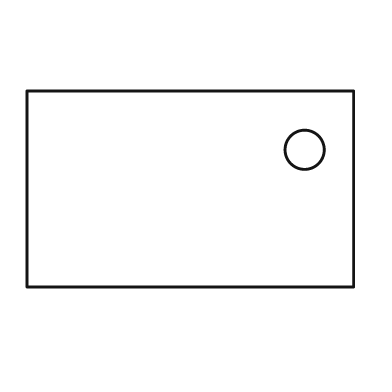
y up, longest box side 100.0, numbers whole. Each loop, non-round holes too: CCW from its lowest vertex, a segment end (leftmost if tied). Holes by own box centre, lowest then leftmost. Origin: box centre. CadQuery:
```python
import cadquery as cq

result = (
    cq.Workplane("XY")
    .moveTo(-50.0, -30.0)
    .lineTo(50.0, -30.0)
    .lineTo(50.0, 30.0)
    .lineTo(-50.0, 30.0)
    .close()
    .moveTo(35.0, 12.0)
    .circle(6.0)
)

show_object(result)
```